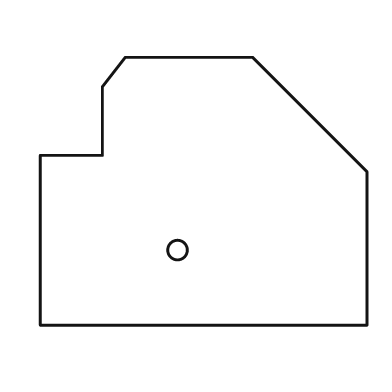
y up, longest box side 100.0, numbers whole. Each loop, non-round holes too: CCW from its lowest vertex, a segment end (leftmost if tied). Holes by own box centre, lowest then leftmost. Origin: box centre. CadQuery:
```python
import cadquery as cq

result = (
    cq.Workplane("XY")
    .moveTo(-50.0, -41.0)
    .lineTo(50.0, -41.0)
    .lineTo(50.0, 6.0)
    .lineTo(15.0, 41.0)
    .lineTo(-24.0, 41.0)
    .lineTo(-31.0, 32.0)
    .lineTo(-31.0, 11.0)
    .lineTo(-50.0, 11.0)
    .close()
    .moveTo(-8.0, -18.0)
    .circle(3.0)
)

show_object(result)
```